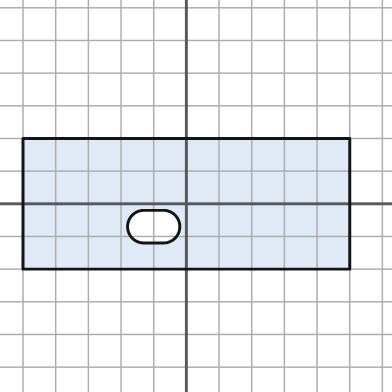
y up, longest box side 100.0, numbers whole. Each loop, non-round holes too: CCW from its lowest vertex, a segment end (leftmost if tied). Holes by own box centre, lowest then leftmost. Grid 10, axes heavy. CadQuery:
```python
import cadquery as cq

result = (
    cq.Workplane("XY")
    .moveTo(-50.0, -20.0)
    .lineTo(50.0, -20.0)
    .lineTo(50.0, 20.0)
    .lineTo(-50.0, 20.0)
    .close()
    .moveTo(-13.0, -12.0)
    .lineTo(-7.0, -12.0)
    .threePointArc((-2.0, -7.0), (-7.0, -2.0))
    .lineTo(-13.0, -2.0)
    .threePointArc((-18.0, -7.0), (-13.0, -12.0))
    .close()
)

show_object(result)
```